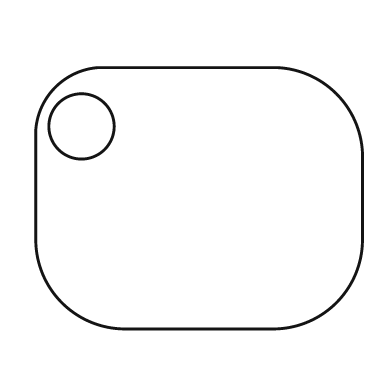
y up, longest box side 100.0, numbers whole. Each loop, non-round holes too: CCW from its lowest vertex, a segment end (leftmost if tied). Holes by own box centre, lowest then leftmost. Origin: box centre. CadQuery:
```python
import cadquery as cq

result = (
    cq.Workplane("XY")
    .moveTo(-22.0, -40.0)
    .lineTo(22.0, -40.0)
    .threePointArc((42.0, -32.0), (50.0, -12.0))
    .lineTo(50.0, 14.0)
    .threePointArc((42.0, 32.0), (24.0, 40.0))
    .lineTo(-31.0, 40.0)
    .threePointArc((-44.0, 34.0), (-50.0, 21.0))
    .lineTo(-50.0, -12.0)
    .threePointArc((-42.0, -32.0), (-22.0, -40.0))
    .close()
    .moveTo(-36.0, 22.0)
    .circle(10.0)
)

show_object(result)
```